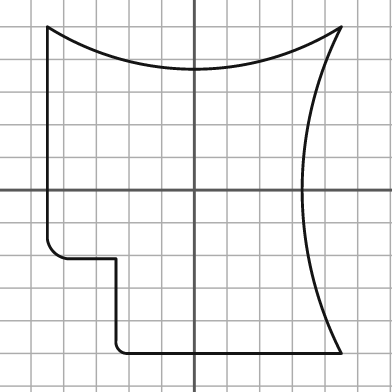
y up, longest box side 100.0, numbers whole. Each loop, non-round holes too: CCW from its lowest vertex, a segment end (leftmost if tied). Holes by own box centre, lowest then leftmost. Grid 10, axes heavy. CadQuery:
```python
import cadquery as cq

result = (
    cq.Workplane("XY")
    .moveTo(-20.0, -50.0)
    .lineTo(45.0, -50.0)
    .threePointArc((33.0, 0.0), (45.0, 50.0))
    .threePointArc((0.0, 37.0), (-45.0, 50.0))
    .lineTo(-45.0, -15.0)
    .threePointArc((-43.0, -19.0), (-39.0, -21.0))
    .lineTo(-24.0, -21.0)
    .lineTo(-24.0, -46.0)
    .threePointArc((-23.0, -49.0), (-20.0, -50.0))
    .close()
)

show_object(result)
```